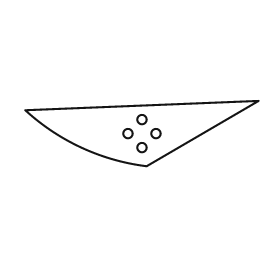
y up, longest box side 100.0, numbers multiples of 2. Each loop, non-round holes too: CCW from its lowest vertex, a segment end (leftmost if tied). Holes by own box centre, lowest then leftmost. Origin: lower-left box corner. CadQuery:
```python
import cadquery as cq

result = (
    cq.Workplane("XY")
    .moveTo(52.0, 0.0)
    .lineTo(100.0, 28.0)
    .lineTo(0.0, 24.0)
    .threePointArc((24.0, 8.0), (52.0, 0.0))
    .close()
    .moveTo(50.0, 8.0)
    .circle(2.0)
    .moveTo(44.0, 14.0)
    .circle(2.0)
    .moveTo(56.0, 14.0)
    .circle(2.0)
    .moveTo(50.0, 20.0)
    .circle(2.0)
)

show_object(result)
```